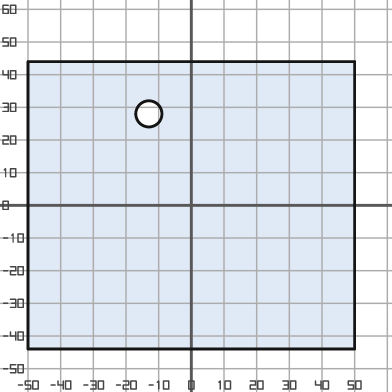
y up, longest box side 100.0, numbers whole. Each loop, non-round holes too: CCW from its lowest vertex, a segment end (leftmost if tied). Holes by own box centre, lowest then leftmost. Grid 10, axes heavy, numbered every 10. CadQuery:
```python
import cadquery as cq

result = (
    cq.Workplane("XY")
    .moveTo(-50.0, -44.0)
    .lineTo(50.0, -44.0)
    .lineTo(50.0, 44.0)
    .lineTo(-50.0, 44.0)
    .close()
    .moveTo(-13.0, 28.0)
    .circle(4.0)
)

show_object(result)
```